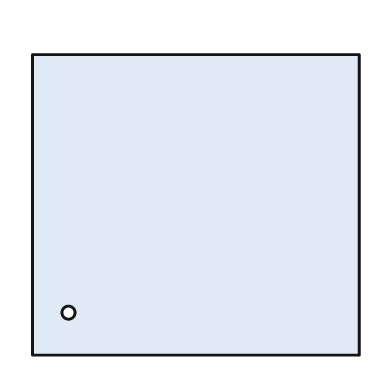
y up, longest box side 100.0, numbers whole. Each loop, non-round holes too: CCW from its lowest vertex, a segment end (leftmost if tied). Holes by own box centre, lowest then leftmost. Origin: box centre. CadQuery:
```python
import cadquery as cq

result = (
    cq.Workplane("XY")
    .moveTo(-50.0, -46.0)
    .lineTo(50.0, -46.0)
    .lineTo(50.0, 46.0)
    .lineTo(-50.0, 46.0)
    .close()
    .moveTo(-39.0, -33.0)
    .circle(2.0)
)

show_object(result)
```